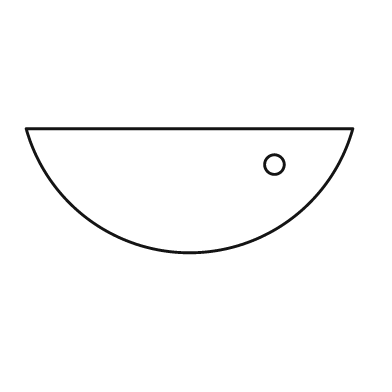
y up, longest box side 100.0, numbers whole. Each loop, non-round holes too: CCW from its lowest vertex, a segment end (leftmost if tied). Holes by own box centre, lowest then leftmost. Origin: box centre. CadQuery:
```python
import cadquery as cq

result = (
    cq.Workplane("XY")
    .moveTo(-50.0, 19.0)
    .threePointArc((0.0, -19.0), (50.0, 19.0))
    .close()
    .moveTo(26.0, 8.0)
    .circle(3.0)
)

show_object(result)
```